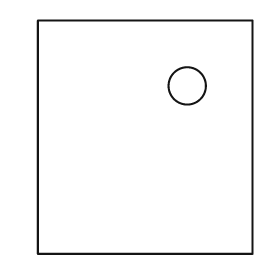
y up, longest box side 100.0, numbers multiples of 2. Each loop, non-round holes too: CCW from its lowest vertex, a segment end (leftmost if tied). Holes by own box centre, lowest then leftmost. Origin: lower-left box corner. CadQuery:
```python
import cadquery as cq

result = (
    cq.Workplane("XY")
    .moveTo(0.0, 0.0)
    .lineTo(92.0, 0.0)
    .lineTo(92.0, 100.0)
    .lineTo(0.0, 100.0)
    .close()
    .moveTo(64.0, 72.0)
    .circle(8.0)
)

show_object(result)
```